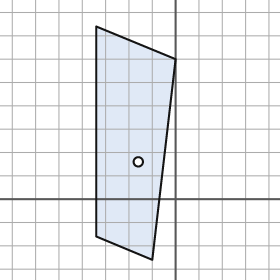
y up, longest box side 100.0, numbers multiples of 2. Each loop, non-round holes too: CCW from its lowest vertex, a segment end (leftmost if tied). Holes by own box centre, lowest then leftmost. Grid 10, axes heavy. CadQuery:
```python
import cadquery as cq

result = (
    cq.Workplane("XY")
    .moveTo(-10.0, -26.0)
    .lineTo(0.0, 60.0)
    .lineTo(-34.0, 74.0)
    .lineTo(-34.0, -16.0)
    .close()
    .moveTo(-16.0, 16.0)
    .circle(2.0)
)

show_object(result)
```